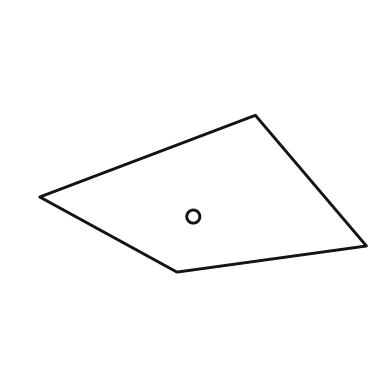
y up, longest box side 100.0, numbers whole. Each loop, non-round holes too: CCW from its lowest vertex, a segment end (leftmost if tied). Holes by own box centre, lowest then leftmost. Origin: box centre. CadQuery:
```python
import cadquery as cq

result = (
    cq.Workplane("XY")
    .moveTo(-8.0, -24.0)
    .lineTo(50.0, -16.0)
    .lineTo(16.0, 24.0)
    .lineTo(-50.0, -1.0)
    .close()
    .moveTo(-3.0, -7.0)
    .circle(2.0)
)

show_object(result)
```